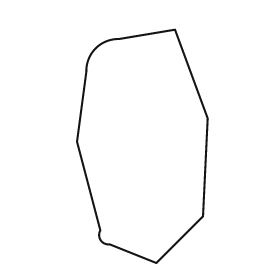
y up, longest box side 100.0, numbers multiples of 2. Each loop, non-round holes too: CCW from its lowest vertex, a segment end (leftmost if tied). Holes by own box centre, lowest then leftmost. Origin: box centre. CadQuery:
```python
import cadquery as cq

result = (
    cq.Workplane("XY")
    .moveTo(6.0, -50.0)
    .lineTo(26.0, -30.0)
    .lineTo(28.0, 12.0)
    .lineTo(14.0, 50.0)
    .lineTo(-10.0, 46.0)
    .threePointArc((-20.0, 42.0), (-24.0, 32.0))
    .lineTo(-28.0, 2.0)
    .lineTo(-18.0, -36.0)
    .threePointArc((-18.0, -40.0), (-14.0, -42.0))
    .close()
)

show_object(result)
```